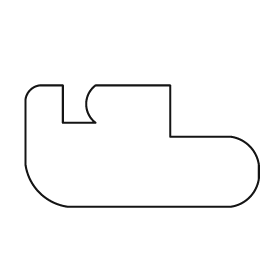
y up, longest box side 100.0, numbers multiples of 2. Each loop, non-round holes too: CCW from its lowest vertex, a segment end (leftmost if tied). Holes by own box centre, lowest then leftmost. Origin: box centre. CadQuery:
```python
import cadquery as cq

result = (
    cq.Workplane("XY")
    .moveTo(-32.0, -26.0)
    .lineTo(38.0, -26.0)
    .threePointArc((46.0, -22.0), (50.0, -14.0))
    .lineTo(50.0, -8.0)
    .threePointArc((46.0, 0.0), (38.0, 4.0))
    .lineTo(12.0, 4.0)
    .lineTo(12.0, 26.0)
    .lineTo(-20.0, 26.0)
    .threePointArc((-24.0, 18.0), (-20.0, 10.0))
    .lineTo(-34.0, 10.0)
    .lineTo(-34.0, 26.0)
    .lineTo(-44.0, 26.0)
    .threePointArc((-48.0, 24.0), (-50.0, 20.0))
    .lineTo(-50.0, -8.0)
    .threePointArc((-44.0, -20.0), (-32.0, -26.0))
    .close()
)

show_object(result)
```